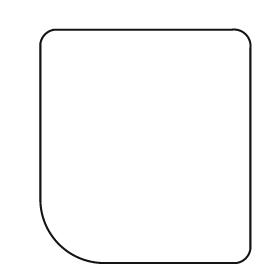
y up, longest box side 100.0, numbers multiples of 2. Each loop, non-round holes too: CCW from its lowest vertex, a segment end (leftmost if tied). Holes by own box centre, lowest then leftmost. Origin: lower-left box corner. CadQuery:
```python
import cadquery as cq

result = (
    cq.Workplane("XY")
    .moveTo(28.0, 0.0)
    .lineTo(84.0, 0.0)
    .threePointArc((88.0, 2.0), (90.0, 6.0))
    .lineTo(90.0, 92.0)
    .threePointArc((88.0, 98.0), (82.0, 100.0))
    .lineTo(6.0, 100.0)
    .threePointArc((2.0, 98.0), (0.0, 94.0))
    .lineTo(0.0, 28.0)
    .threePointArc((8.0, 8.0), (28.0, 0.0))
    .close()
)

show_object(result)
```